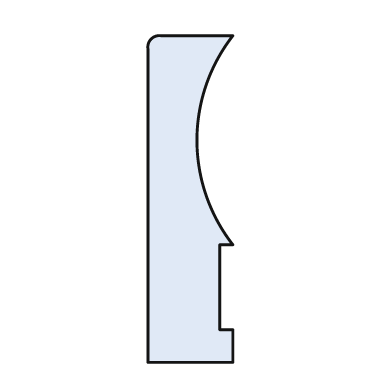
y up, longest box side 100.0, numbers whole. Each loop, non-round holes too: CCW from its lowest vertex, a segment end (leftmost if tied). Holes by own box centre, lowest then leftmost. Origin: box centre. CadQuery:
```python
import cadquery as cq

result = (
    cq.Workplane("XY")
    .moveTo(-13.0, -50.0)
    .lineTo(13.0, -50.0)
    .lineTo(13.0, -40.0)
    .lineTo(9.0, -40.0)
    .lineTo(9.0, -14.0)
    .lineTo(13.0, -14.0)
    .threePointArc((2.0, 18.0), (13.0, 50.0))
    .lineTo(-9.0, 50.0)
    .threePointArc((-12.0, 49.0), (-13.0, 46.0))
    .close()
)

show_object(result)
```